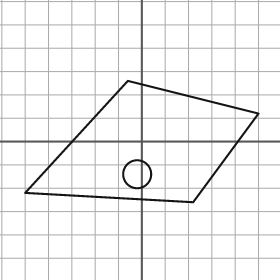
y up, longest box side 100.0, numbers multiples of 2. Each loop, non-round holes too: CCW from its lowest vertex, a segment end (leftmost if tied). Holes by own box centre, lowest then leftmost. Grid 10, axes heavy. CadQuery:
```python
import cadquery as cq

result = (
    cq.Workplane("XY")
    .moveTo(22.0, -26.0)
    .lineTo(50.0, 12.0)
    .lineTo(-6.0, 26.0)
    .lineTo(-50.0, -22.0)
    .close()
    .moveTo(-2.0, -14.0)
    .circle(6.0)
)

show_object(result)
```